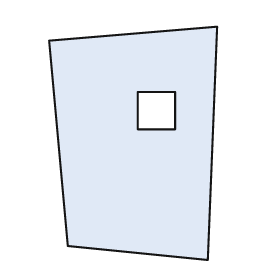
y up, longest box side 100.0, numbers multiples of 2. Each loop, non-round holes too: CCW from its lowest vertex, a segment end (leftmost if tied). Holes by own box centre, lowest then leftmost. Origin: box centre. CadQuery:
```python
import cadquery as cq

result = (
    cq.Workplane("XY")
    .moveTo(32.0, -50.0)
    .lineTo(36.0, 50.0)
    .lineTo(-36.0, 44.0)
    .lineTo(-28.0, -44.0)
    .close()
    .moveTo(2.0, 6.0)
    .lineTo(18.0, 6.0)
    .lineTo(18.0, 22.0)
    .lineTo(2.0, 22.0)
    .close()
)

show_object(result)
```